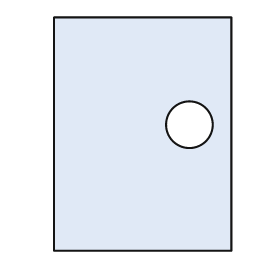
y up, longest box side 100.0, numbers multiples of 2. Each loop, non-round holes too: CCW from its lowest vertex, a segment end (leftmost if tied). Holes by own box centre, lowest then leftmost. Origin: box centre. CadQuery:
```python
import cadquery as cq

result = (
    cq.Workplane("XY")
    .moveTo(-38.0, -50.0)
    .lineTo(38.0, -50.0)
    .lineTo(38.0, 50.0)
    .lineTo(-38.0, 50.0)
    .close()
    .moveTo(20.0, 4.0)
    .circle(10.0)
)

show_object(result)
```